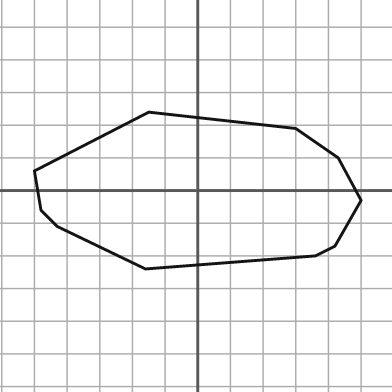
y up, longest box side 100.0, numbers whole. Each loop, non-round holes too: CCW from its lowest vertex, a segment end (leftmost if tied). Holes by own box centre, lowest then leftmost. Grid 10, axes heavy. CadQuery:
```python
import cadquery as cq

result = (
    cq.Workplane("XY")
    .moveTo(-16.0, -24.0)
    .lineTo(36.0, -20.0)
    .lineTo(42.0, -17.0)
    .lineTo(50.0, -3.0)
    .lineTo(43.0, 10.0)
    .lineTo(30.0, 19.0)
    .lineTo(-15.0, 24.0)
    .lineTo(-50.0, 6.0)
    .lineTo(-48.0, -6.0)
    .lineTo(-43.0, -11.0)
    .close()
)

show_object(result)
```